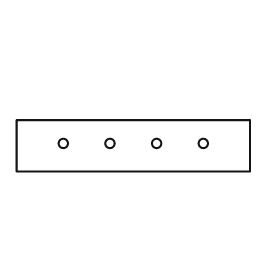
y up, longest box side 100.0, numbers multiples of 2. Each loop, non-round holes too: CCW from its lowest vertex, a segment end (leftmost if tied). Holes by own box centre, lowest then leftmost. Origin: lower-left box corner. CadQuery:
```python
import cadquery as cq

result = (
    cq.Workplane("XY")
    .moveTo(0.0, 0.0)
    .lineTo(100.0, 0.0)
    .lineTo(100.0, 22.0)
    .lineTo(0.0, 22.0)
    .close()
    .moveTo(20.0, 12.0)
    .circle(2.0)
    .moveTo(40.0, 12.0)
    .circle(2.0)
    .moveTo(60.0, 12.0)
    .circle(2.0)
    .moveTo(80.0, 12.0)
    .circle(2.0)
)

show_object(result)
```